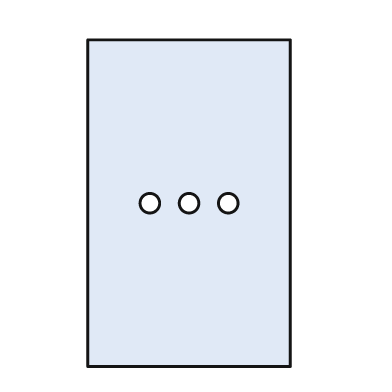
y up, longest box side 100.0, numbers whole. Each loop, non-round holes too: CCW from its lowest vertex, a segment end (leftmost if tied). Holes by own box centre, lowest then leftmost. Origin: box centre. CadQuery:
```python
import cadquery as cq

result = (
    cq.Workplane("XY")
    .moveTo(-31.0, -50.0)
    .lineTo(31.0, -50.0)
    .lineTo(31.0, 50.0)
    .lineTo(-31.0, 50.0)
    .close()
    .moveTo(-12.0, 0.0)
    .circle(3.0)
    .moveTo(0.0, 0.0)
    .circle(3.0)
    .moveTo(12.0, 0.0)
    .circle(3.0)
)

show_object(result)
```